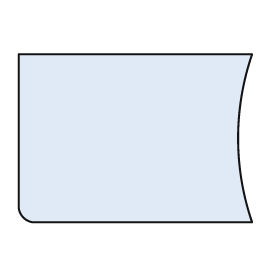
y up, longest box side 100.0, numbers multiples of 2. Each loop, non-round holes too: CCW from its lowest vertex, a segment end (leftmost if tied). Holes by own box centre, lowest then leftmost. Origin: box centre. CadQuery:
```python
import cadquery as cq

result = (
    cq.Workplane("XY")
    .moveTo(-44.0, -36.0)
    .lineTo(50.0, -36.0)
    .threePointArc((44.0, 0.0), (50.0, 36.0))
    .lineTo(-50.0, 36.0)
    .lineTo(-50.0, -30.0)
    .threePointArc((-48.0, -34.0), (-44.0, -36.0))
    .close()
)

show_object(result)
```